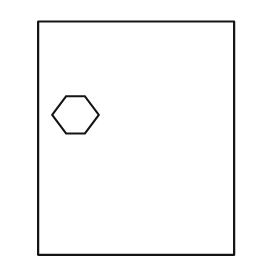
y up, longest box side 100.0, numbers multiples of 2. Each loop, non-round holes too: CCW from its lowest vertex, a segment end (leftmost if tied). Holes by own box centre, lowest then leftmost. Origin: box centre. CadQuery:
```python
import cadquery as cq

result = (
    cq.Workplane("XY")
    .moveTo(-42.0, -50.0)
    .lineTo(42.0, -50.0)
    .lineTo(42.0, 50.0)
    .lineTo(-42.0, 50.0)
    .close()
    .moveTo(-30.0, 2.0)
    .lineTo(-22.0, 2.0)
    .lineTo(-16.0, 10.0)
    .lineTo(-22.0, 18.0)
    .lineTo(-30.0, 18.0)
    .lineTo(-36.0, 10.0)
    .close()
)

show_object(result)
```